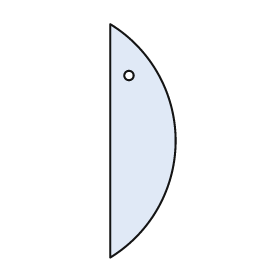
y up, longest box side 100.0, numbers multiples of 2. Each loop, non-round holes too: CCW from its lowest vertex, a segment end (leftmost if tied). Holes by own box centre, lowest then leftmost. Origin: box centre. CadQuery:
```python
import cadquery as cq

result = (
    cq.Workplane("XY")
    .moveTo(-14.0, -50.0)
    .threePointArc((14.0, 0.0), (-14.0, 50.0))
    .close()
    .moveTo(-6.0, 28.0)
    .circle(2.0)
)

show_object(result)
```